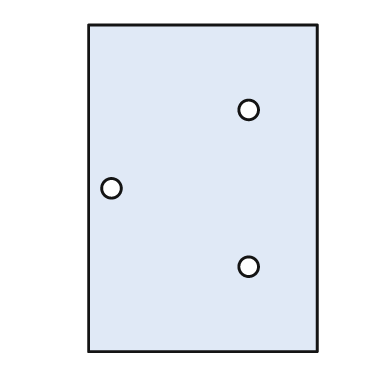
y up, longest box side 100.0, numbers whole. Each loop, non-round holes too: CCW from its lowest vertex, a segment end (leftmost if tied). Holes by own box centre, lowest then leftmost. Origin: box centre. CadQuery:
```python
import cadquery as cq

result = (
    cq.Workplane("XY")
    .moveTo(-35.0, -50.0)
    .lineTo(35.0, -50.0)
    .lineTo(35.0, 50.0)
    .lineTo(-35.0, 50.0)
    .close()
    .moveTo(14.0, -24.0)
    .circle(3.0)
    .moveTo(-28.0, 0.0)
    .circle(3.0)
    .moveTo(14.0, 24.0)
    .circle(3.0)
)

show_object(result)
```